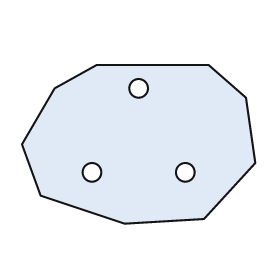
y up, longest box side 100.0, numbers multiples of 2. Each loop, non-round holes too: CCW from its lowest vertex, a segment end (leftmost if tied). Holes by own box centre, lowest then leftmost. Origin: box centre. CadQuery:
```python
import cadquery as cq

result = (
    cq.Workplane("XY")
    .moveTo(-6.0, -34.0)
    .lineTo(28.0, -32.0)
    .lineTo(50.0, -8.0)
    .lineTo(46.0, 20.0)
    .lineTo(30.0, 34.0)
    .lineTo(-18.0, 34.0)
    .lineTo(-36.0, 24.0)
    .lineTo(-50.0, 0.0)
    .lineTo(-42.0, -22.0)
    .close()
    .moveTo(-20.0, -12.0)
    .circle(4.0)
    .moveTo(20.0, -12.0)
    .circle(4.0)
    .moveTo(0.0, 24.0)
    .circle(4.0)
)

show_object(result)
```